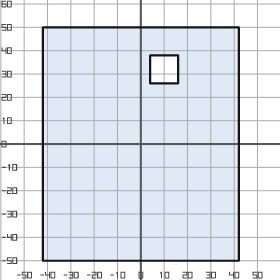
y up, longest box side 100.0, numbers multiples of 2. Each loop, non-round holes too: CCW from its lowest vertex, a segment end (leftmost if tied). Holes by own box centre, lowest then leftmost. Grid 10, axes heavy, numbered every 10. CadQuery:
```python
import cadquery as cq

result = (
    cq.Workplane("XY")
    .moveTo(-42.0, -50.0)
    .lineTo(42.0, -50.0)
    .lineTo(42.0, 50.0)
    .lineTo(-42.0, 50.0)
    .close()
    .moveTo(4.0, 26.0)
    .lineTo(16.0, 26.0)
    .lineTo(16.0, 38.0)
    .lineTo(4.0, 38.0)
    .close()
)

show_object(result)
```